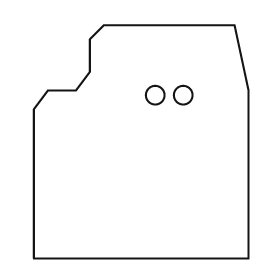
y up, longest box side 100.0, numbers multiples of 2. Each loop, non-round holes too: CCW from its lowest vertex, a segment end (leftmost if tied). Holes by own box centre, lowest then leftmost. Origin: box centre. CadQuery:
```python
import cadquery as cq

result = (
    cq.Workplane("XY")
    .moveTo(-46.0, -50.0)
    .lineTo(46.0, -50.0)
    .lineTo(46.0, 22.0)
    .lineTo(40.0, 50.0)
    .lineTo(-16.0, 50.0)
    .lineTo(-22.0, 44.0)
    .lineTo(-22.0, 30.0)
    .lineTo(-28.0, 22.0)
    .lineTo(-40.0, 22.0)
    .lineTo(-46.0, 14.0)
    .close()
    .moveTo(6.0, 20.0)
    .circle(4.0)
    .moveTo(18.0, 20.0)
    .circle(4.0)
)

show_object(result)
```